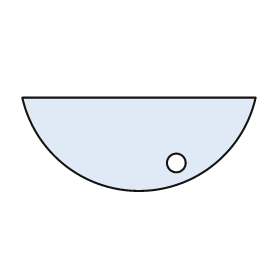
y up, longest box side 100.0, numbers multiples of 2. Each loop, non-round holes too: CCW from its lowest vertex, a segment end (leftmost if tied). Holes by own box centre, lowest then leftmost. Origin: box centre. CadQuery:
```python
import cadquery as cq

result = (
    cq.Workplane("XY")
    .moveTo(-50.0, 20.0)
    .threePointArc((0.0, -20.0), (50.0, 20.0))
    .close()
    .moveTo(16.0, -8.0)
    .circle(4.0)
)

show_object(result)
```